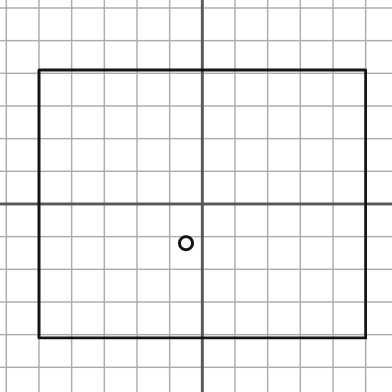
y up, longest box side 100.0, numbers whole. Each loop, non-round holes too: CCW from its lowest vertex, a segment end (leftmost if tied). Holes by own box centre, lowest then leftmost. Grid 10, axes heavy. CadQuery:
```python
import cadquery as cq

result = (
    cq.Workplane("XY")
    .moveTo(-50.0, -41.0)
    .lineTo(50.0, -41.0)
    .lineTo(50.0, 41.0)
    .lineTo(-50.0, 41.0)
    .close()
    .moveTo(-5.0, -12.0)
    .circle(2.0)
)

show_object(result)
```